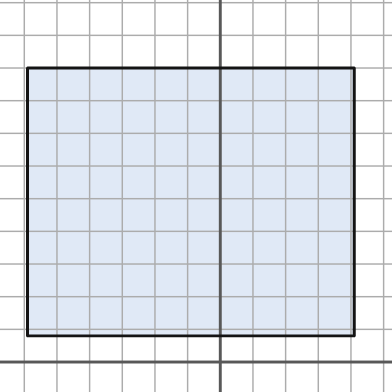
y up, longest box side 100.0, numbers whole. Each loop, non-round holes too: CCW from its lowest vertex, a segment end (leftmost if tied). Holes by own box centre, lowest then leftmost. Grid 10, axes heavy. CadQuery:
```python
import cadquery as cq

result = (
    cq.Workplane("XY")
    .moveTo(-59.0, 8.0)
    .lineTo(41.0, 8.0)
    .lineTo(41.0, 90.0)
    .lineTo(-59.0, 90.0)
    .close()
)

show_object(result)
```